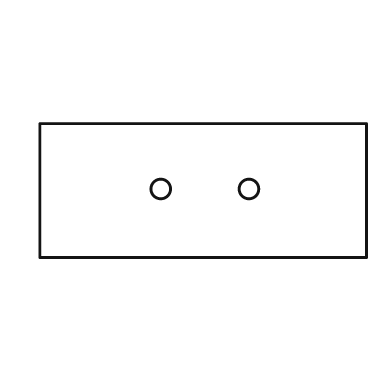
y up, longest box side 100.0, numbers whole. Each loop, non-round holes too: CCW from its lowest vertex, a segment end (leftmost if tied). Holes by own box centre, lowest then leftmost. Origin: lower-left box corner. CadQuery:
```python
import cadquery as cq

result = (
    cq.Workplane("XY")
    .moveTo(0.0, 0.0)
    .lineTo(100.0, 0.0)
    .lineTo(100.0, 41.0)
    .lineTo(0.0, 41.0)
    .close()
    .moveTo(37.0, 21.0)
    .circle(3.0)
    .moveTo(64.0, 21.0)
    .circle(3.0)
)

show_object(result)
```